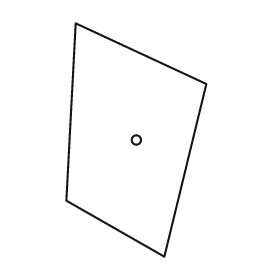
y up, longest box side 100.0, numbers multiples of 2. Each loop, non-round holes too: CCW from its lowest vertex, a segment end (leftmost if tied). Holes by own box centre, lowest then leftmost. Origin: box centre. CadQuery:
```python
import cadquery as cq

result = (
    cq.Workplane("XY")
    .moveTo(12.0, -50.0)
    .lineTo(30.0, 24.0)
    .lineTo(-26.0, 50.0)
    .lineTo(-30.0, -26.0)
    .close()
    .moveTo(0.0, 0.0)
    .circle(2.0)
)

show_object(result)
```